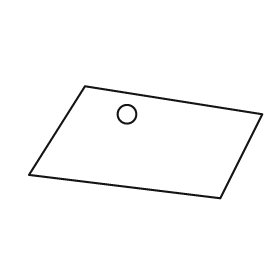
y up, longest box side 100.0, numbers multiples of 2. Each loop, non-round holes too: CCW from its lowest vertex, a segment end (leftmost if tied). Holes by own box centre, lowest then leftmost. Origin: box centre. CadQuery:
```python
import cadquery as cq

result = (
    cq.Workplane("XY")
    .moveTo(32.0, -24.0)
    .lineTo(50.0, 12.0)
    .lineTo(-26.0, 24.0)
    .lineTo(-50.0, -14.0)
    .close()
    .moveTo(-8.0, 12.0)
    .circle(4.0)
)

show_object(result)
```